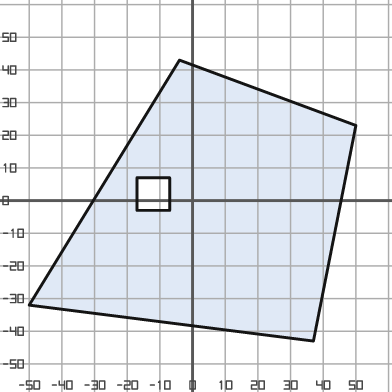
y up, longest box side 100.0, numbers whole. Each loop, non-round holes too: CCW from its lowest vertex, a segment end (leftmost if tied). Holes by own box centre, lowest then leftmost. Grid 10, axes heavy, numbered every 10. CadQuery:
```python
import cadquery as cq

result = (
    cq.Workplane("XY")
    .moveTo(37.0, -43.0)
    .lineTo(50.0, 23.0)
    .lineTo(-4.0, 43.0)
    .lineTo(-50.0, -32.0)
    .close()
    .moveTo(-17.0, -3.0)
    .lineTo(-7.0, -3.0)
    .lineTo(-7.0, 7.0)
    .lineTo(-17.0, 7.0)
    .close()
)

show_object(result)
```